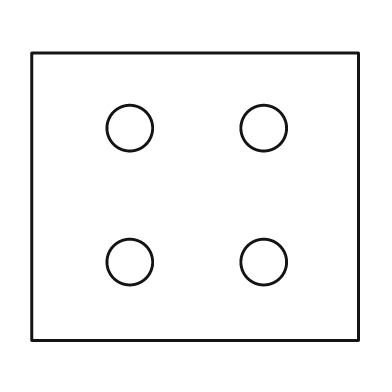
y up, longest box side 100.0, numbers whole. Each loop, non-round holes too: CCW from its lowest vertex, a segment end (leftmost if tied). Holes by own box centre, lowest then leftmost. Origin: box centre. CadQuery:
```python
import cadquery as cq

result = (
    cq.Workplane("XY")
    .moveTo(-50.0, -44.0)
    .lineTo(50.0, -44.0)
    .lineTo(50.0, 44.0)
    .lineTo(-50.0, 44.0)
    .close()
    .moveTo(-20.0, -20.0)
    .circle(7.0)
    .moveTo(21.0, -20.0)
    .circle(7.0)
    .moveTo(-20.0, 21.0)
    .circle(7.0)
    .moveTo(21.0, 21.0)
    .circle(7.0)
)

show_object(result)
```